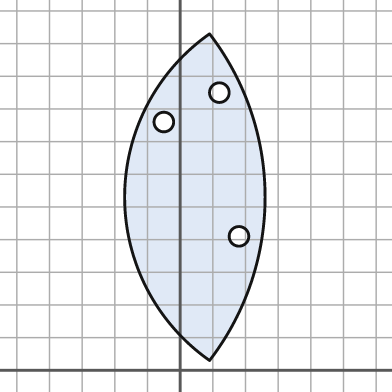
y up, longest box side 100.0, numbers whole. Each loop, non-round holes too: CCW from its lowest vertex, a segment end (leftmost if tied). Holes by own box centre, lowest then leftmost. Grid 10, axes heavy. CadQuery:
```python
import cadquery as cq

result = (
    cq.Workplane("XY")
    .moveTo(9.0, 3.0)
    .threePointArc((26.0, 53.0), (9.0, 103.0))
    .threePointArc((-17.0, 53.0), (9.0, 3.0))
    .close()
    .moveTo(18.0, 41.0)
    .circle(3.0)
    .moveTo(-5.0, 76.0)
    .circle(3.0)
    .moveTo(12.0, 85.0)
    .circle(3.0)
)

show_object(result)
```